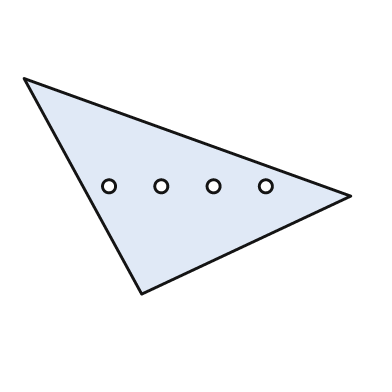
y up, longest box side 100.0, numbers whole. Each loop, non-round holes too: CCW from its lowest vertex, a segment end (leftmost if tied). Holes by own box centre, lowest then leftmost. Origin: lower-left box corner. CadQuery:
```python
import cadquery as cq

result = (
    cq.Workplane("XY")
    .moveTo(36.0, 0.0)
    .lineTo(100.0, 30.0)
    .lineTo(0.0, 66.0)
    .close()
    .moveTo(26.0, 33.0)
    .circle(2.0)
    .moveTo(42.0, 33.0)
    .circle(2.0)
    .moveTo(58.0, 33.0)
    .circle(2.0)
    .moveTo(74.0, 33.0)
    .circle(2.0)
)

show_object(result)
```